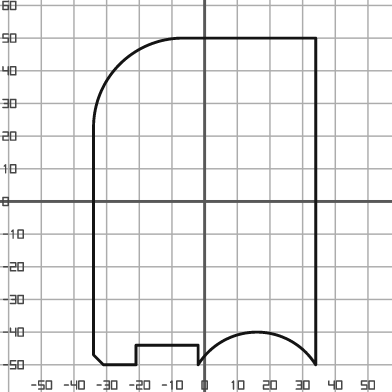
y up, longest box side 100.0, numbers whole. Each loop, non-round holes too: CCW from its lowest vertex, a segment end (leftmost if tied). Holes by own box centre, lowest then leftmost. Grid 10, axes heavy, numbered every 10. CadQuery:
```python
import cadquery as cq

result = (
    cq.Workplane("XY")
    .moveTo(-31.0, -50.0)
    .lineTo(-21.0, -50.0)
    .lineTo(-21.0, -44.0)
    .lineTo(-2.0, -44.0)
    .lineTo(-2.0, -50.0)
    .threePointArc((16.0, -40.0), (34.0, -50.0))
    .lineTo(34.0, 50.0)
    .lineTo(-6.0, 50.0)
    .threePointArc((-26.0, 42.0), (-34.0, 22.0))
    .lineTo(-34.0, -47.0)
    .close()
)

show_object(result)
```